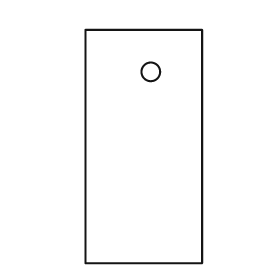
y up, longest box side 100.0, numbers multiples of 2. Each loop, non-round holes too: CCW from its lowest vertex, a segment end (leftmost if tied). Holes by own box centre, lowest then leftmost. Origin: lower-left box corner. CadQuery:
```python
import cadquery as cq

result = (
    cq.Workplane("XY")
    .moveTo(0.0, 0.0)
    .lineTo(50.0, 0.0)
    .lineTo(50.0, 100.0)
    .lineTo(0.0, 100.0)
    .close()
    .moveTo(28.0, 82.0)
    .circle(4.0)
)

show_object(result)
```